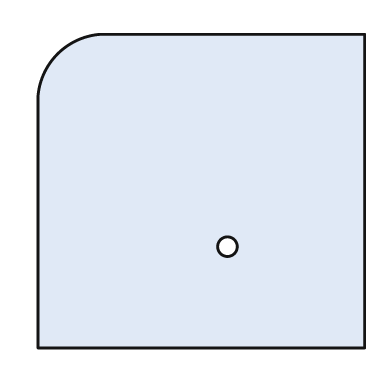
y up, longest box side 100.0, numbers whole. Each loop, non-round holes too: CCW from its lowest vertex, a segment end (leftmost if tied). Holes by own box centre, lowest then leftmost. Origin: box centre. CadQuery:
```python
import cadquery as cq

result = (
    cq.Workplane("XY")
    .moveTo(-50.0, -48.0)
    .lineTo(50.0, -48.0)
    .lineTo(50.0, 48.0)
    .lineTo(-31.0, 48.0)
    .threePointArc((-44.0, 42.0), (-50.0, 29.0))
    .close()
    .moveTo(8.0, -17.0)
    .circle(3.0)
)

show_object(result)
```